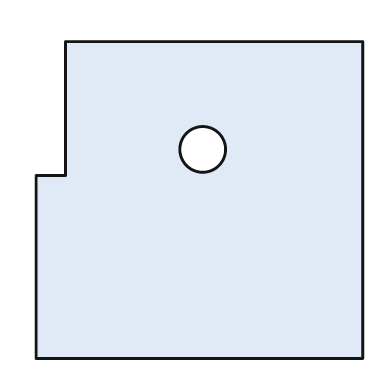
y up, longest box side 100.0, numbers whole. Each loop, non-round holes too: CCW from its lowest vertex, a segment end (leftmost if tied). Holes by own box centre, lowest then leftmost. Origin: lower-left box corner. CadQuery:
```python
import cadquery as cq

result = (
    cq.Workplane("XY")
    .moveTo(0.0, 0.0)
    .lineTo(100.0, 0.0)
    .lineTo(100.0, 97.0)
    .lineTo(9.0, 97.0)
    .lineTo(9.0, 56.0)
    .lineTo(0.0, 56.0)
    .close()
    .moveTo(51.0, 64.0)
    .circle(7.0)
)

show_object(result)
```